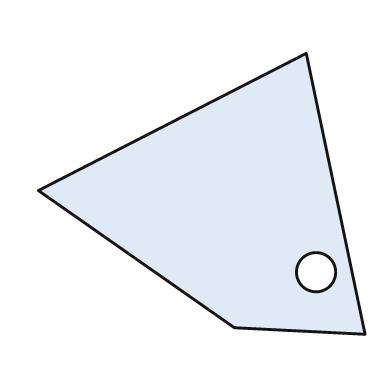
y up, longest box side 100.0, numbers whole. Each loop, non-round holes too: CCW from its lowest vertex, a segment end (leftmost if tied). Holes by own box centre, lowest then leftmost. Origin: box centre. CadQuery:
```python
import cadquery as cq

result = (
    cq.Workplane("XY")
    .moveTo(50.0, -43.0)
    .lineTo(32.0, 43.0)
    .lineTo(-50.0, 1.0)
    .lineTo(10.0, -41.0)
    .close()
    .moveTo(35.0, -24.0)
    .circle(6.0)
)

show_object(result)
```